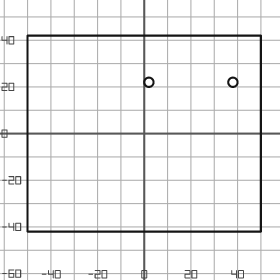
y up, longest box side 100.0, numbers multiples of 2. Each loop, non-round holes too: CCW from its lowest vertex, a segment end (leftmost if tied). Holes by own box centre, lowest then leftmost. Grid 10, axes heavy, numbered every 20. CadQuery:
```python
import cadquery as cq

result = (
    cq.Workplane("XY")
    .moveTo(-50.0, -42.0)
    .lineTo(50.0, -42.0)
    .lineTo(50.0, 42.0)
    .lineTo(-50.0, 42.0)
    .close()
    .moveTo(2.0, 22.0)
    .circle(2.0)
    .moveTo(38.0, 22.0)
    .circle(2.0)
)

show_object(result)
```